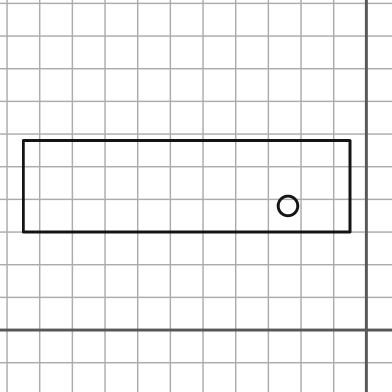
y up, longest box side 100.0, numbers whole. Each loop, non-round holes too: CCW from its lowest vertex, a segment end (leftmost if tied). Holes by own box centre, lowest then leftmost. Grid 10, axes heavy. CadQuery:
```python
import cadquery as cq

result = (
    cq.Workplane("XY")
    .moveTo(-105.0, 30.0)
    .lineTo(-5.0, 30.0)
    .lineTo(-5.0, 58.0)
    .lineTo(-105.0, 58.0)
    .close()
    .moveTo(-24.0, 38.0)
    .circle(3.0)
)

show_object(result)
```